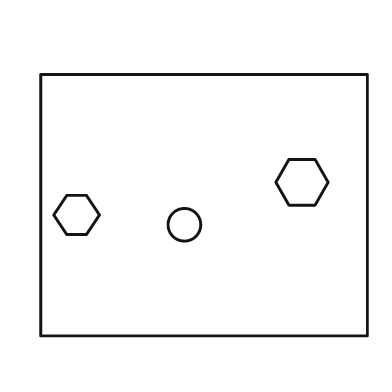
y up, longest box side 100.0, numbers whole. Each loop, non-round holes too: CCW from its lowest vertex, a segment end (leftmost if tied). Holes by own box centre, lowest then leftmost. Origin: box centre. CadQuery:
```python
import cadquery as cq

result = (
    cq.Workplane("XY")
    .moveTo(-50.0, -40.0)
    .lineTo(50.0, -40.0)
    .lineTo(50.0, 40.0)
    .lineTo(-50.0, 40.0)
    .close()
    .moveTo(-6.0, -6.0)
    .circle(5.0)
    .moveTo(-42.0, -9.0)
    .lineTo(-36.0, -9.0)
    .lineTo(-32.0, -3.0)
    .lineTo(-36.0, 3.0)
    .lineTo(-42.0, 3.0)
    .lineTo(-46.0, -3.0)
    .close()
    .moveTo(26.0, 0.0)
    .lineTo(34.0, 0.0)
    .lineTo(38.0, 7.0)
    .lineTo(34.0, 14.0)
    .lineTo(26.0, 14.0)
    .lineTo(22.0, 7.0)
    .close()
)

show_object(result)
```